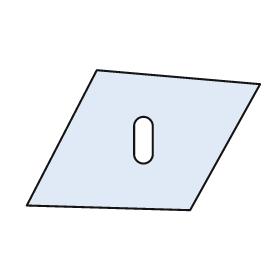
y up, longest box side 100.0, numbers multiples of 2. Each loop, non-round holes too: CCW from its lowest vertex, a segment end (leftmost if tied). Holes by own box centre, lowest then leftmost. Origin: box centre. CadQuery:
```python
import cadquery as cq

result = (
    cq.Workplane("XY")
    .moveTo(20.0, -30.0)
    .lineTo(50.0, 24.0)
    .lineTo(-20.0, 30.0)
    .lineTo(-50.0, -28.0)
    .close()
    .moveTo(-4.0, -6.0)
    .threePointArc((0.0, -10.0), (4.0, -6.0))
    .lineTo(4.0, 6.0)
    .threePointArc((0.0, 10.0), (-4.0, 6.0))
    .close()
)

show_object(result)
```